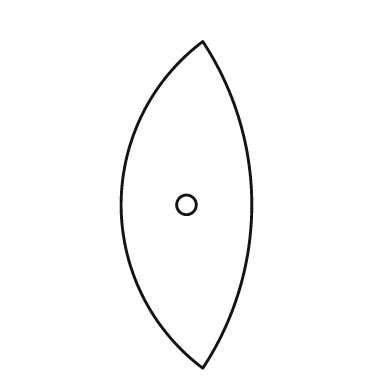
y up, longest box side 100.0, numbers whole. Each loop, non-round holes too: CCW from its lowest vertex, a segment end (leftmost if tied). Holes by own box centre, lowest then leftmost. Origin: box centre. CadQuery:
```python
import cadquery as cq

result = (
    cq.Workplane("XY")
    .moveTo(5.0, -50.0)
    .threePointArc((20.0, 0.0), (5.0, 50.0))
    .threePointArc((-20.0, 0.0), (5.0, -50.0))
    .close()
    .moveTo(0.0, 0.0)
    .circle(3.0)
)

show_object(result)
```